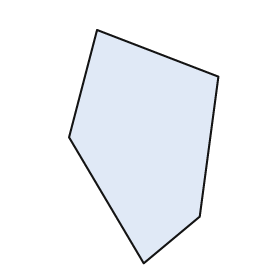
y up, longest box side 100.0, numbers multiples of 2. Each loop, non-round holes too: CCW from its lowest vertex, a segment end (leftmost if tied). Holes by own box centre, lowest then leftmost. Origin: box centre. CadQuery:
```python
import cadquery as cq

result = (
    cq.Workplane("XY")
    .moveTo(0.0, -50.0)
    .lineTo(24.0, -30.0)
    .lineTo(32.0, 30.0)
    .lineTo(-20.0, 50.0)
    .lineTo(-32.0, 4.0)
    .close()
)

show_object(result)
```